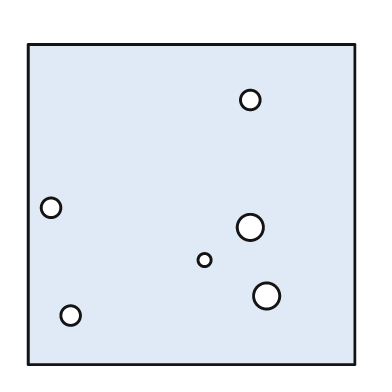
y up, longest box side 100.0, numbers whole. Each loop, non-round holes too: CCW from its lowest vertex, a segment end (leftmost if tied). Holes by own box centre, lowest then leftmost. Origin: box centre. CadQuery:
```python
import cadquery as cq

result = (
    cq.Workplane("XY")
    .moveTo(-50.0, -49.0)
    .lineTo(50.0, -49.0)
    .lineTo(50.0, 49.0)
    .lineTo(-50.0, 49.0)
    .close()
    .moveTo(-37.0, -34.0)
    .circle(3.0)
    .moveTo(23.0, -28.0)
    .circle(4.0)
    .moveTo(4.0, -17.0)
    .circle(2.0)
    .moveTo(18.0, -7.0)
    .circle(4.0)
    .moveTo(-43.0, -1.0)
    .circle(3.0)
    .moveTo(18.0, 32.0)
    .circle(3.0)
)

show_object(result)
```